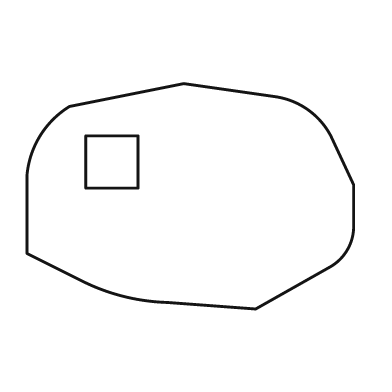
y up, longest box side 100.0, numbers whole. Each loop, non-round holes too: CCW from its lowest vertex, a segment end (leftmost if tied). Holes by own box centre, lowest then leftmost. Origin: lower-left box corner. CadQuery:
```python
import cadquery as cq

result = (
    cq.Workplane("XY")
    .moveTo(70.0, 0.0)
    .lineTo(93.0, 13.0)
    .threePointArc((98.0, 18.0), (100.0, 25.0))
    .lineTo(100.0, 38.0)
    .lineTo(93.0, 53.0)
    .threePointArc((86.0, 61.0), (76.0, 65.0))
    .lineTo(48.0, 69.0)
    .lineTo(13.0, 62.0)
    .threePointArc((4.0, 53.0), (0.0, 41.0))
    .lineTo(0.0, 17.0)
    .lineTo(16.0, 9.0)
    .threePointArc((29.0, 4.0), (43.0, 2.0))
    .close()
    .moveTo(18.0, 37.0)
    .lineTo(34.0, 37.0)
    .lineTo(34.0, 53.0)
    .lineTo(18.0, 53.0)
    .close()
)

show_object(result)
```